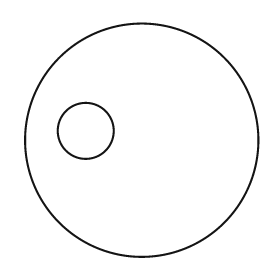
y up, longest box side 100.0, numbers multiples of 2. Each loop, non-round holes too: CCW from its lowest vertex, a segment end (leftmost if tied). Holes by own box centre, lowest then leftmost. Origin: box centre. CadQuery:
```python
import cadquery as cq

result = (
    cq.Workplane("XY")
    .moveTo(0.0, 0.0)
    .circle(50.0)
    .moveTo(-24.0, 4.0)
    .circle(12.0)
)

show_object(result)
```